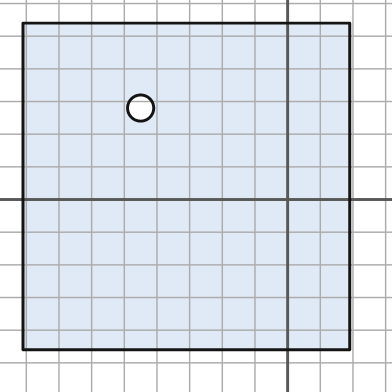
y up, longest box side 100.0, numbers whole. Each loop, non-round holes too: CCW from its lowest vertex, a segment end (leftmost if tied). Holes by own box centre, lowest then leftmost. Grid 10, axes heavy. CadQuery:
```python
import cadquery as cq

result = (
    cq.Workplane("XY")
    .moveTo(-81.0, -46.0)
    .lineTo(19.0, -46.0)
    .lineTo(19.0, 54.0)
    .lineTo(-81.0, 54.0)
    .close()
    .moveTo(-45.0, 28.0)
    .circle(4.0)
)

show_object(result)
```